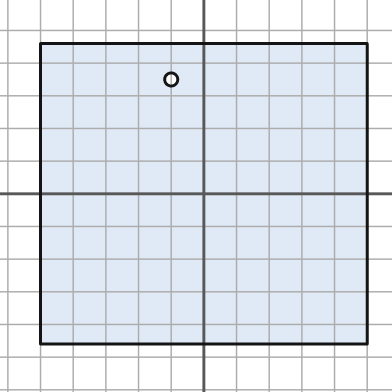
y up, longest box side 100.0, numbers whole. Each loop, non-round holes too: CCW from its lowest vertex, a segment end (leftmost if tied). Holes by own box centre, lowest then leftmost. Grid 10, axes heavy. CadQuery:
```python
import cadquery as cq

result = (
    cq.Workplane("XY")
    .moveTo(-50.0, -46.0)
    .lineTo(50.0, -46.0)
    .lineTo(50.0, 46.0)
    .lineTo(-50.0, 46.0)
    .close()
    .moveTo(-10.0, 35.0)
    .circle(2.0)
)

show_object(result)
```